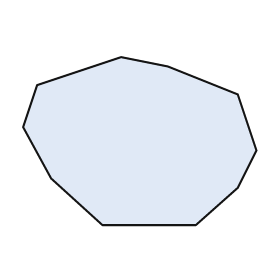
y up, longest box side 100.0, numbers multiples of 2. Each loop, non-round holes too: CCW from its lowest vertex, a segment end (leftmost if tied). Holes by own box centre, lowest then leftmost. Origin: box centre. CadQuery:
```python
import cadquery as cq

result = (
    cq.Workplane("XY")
    .moveTo(-16.0, -36.0)
    .lineTo(24.0, -36.0)
    .lineTo(42.0, -20.0)
    .lineTo(50.0, -4.0)
    .lineTo(42.0, 20.0)
    .lineTo(12.0, 32.0)
    .lineTo(-8.0, 36.0)
    .lineTo(-44.0, 24.0)
    .lineTo(-50.0, 6.0)
    .lineTo(-38.0, -16.0)
    .close()
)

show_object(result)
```